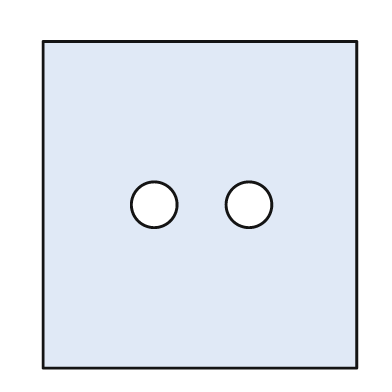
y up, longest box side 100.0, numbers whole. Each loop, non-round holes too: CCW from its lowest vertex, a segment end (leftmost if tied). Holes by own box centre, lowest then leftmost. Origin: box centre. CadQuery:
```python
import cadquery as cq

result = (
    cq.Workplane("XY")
    .moveTo(-48.0, -50.0)
    .lineTo(48.0, -50.0)
    .lineTo(48.0, 50.0)
    .lineTo(-48.0, 50.0)
    .close()
    .moveTo(-14.0, 0.0)
    .circle(7.0)
    .moveTo(15.0, 0.0)
    .circle(7.0)
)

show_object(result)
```